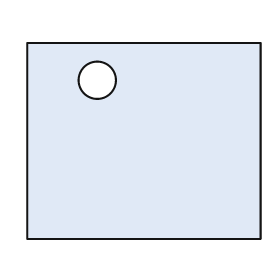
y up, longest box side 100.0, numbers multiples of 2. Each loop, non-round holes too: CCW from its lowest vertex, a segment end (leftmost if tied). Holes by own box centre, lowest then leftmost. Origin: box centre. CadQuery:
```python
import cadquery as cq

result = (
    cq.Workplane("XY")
    .moveTo(-50.0, -42.0)
    .lineTo(50.0, -42.0)
    .lineTo(50.0, 42.0)
    .lineTo(-50.0, 42.0)
    .close()
    .moveTo(-20.0, 26.0)
    .circle(8.0)
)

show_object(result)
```